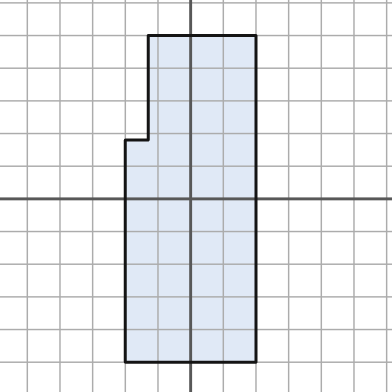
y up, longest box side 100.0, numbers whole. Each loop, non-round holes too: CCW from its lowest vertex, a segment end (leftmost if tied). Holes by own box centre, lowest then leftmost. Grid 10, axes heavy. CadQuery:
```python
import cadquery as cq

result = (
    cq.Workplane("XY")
    .moveTo(-20.0, -50.0)
    .lineTo(20.0, -50.0)
    .lineTo(20.0, 50.0)
    .lineTo(-13.0, 50.0)
    .lineTo(-13.0, 18.0)
    .lineTo(-20.0, 18.0)
    .close()
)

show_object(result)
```